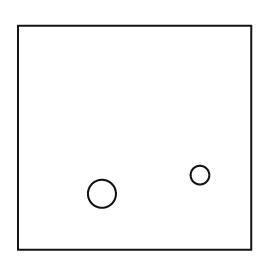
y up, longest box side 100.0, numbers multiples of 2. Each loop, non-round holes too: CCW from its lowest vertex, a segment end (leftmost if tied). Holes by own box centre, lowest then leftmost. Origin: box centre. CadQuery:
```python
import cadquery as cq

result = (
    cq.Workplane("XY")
    .moveTo(-50.0, -48.0)
    .lineTo(50.0, -48.0)
    .lineTo(50.0, 48.0)
    .lineTo(-50.0, 48.0)
    .close()
    .moveTo(-14.0, -24.0)
    .circle(6.0)
    .moveTo(28.0, -16.0)
    .circle(4.0)
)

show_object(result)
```